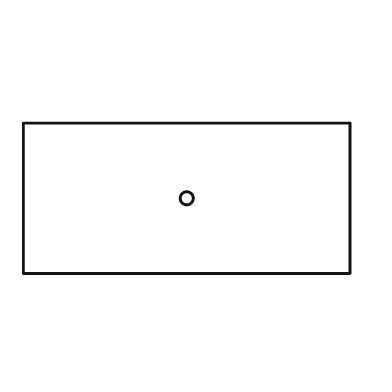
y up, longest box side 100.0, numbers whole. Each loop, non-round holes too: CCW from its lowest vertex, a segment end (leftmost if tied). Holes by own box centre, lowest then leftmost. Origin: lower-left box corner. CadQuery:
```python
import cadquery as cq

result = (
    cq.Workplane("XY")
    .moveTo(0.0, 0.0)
    .lineTo(100.0, 0.0)
    .lineTo(100.0, 46.0)
    .lineTo(0.0, 46.0)
    .close()
    .moveTo(50.0, 23.0)
    .circle(2.0)
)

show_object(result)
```